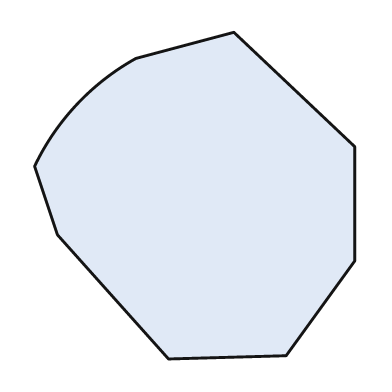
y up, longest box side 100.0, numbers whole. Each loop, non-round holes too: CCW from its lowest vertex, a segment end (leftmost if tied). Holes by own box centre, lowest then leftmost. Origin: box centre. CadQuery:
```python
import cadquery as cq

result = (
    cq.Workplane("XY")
    .moveTo(-8.0, -50.0)
    .lineTo(28.0, -49.0)
    .lineTo(49.0, -20.0)
    .lineTo(49.0, 15.0)
    .lineTo(12.0, 50.0)
    .lineTo(-18.0, 42.0)
    .threePointArc((-36.0, 28.0), (-49.0, 9.0))
    .lineTo(-42.0, -12.0)
    .close()
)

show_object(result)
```